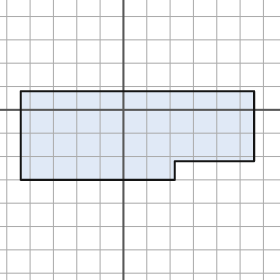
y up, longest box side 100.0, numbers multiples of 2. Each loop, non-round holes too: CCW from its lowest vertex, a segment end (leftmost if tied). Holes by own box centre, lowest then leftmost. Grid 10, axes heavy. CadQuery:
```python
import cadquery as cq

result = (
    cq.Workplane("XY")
    .moveTo(-44.0, -30.0)
    .lineTo(22.0, -30.0)
    .lineTo(22.0, -22.0)
    .lineTo(56.0, -22.0)
    .lineTo(56.0, 8.0)
    .lineTo(-44.0, 8.0)
    .close()
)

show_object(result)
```